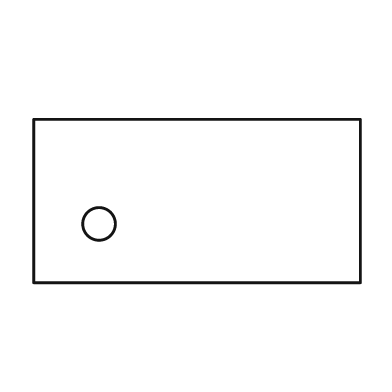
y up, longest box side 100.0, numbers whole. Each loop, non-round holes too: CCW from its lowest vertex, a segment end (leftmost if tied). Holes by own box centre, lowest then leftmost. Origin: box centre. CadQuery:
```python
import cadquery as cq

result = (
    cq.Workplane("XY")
    .moveTo(-50.0, -25.0)
    .lineTo(50.0, -25.0)
    .lineTo(50.0, 25.0)
    .lineTo(-50.0, 25.0)
    .close()
    .moveTo(-30.0, -7.0)
    .circle(5.0)
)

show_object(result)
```